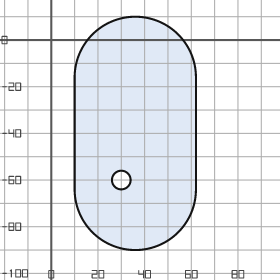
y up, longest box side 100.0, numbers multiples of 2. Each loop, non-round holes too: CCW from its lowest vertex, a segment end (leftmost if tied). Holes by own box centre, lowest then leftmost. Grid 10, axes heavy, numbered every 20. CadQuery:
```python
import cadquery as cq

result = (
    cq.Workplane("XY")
    .moveTo(10.0, -64.0)
    .threePointArc((36.0, -90.0), (62.0, -64.0))
    .lineTo(62.0, -16.0)
    .threePointArc((36.0, 10.0), (10.0, -16.0))
    .close()
    .moveTo(30.0, -60.0)
    .circle(4.0)
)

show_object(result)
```